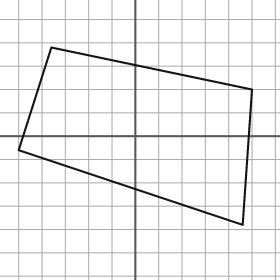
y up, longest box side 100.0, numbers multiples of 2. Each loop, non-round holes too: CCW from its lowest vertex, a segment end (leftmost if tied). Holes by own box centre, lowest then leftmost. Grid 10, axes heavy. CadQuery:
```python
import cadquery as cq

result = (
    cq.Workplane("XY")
    .moveTo(46.0, -38.0)
    .lineTo(50.0, 20.0)
    .lineTo(-36.0, 38.0)
    .lineTo(-50.0, -6.0)
    .close()
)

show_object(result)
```